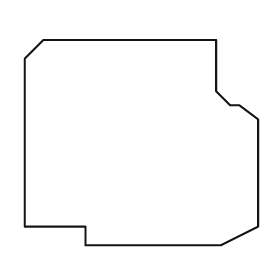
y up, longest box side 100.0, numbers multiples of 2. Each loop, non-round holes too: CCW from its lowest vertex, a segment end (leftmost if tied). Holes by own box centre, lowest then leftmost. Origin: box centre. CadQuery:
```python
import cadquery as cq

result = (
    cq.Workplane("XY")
    .moveTo(-24.0, -44.0)
    .lineTo(34.0, -44.0)
    .lineTo(50.0, -36.0)
    .lineTo(50.0, 10.0)
    .lineTo(42.0, 16.0)
    .lineTo(38.0, 16.0)
    .lineTo(32.0, 22.0)
    .lineTo(32.0, 44.0)
    .lineTo(-42.0, 44.0)
    .lineTo(-50.0, 36.0)
    .lineTo(-50.0, -36.0)
    .lineTo(-24.0, -36.0)
    .close()
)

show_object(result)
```